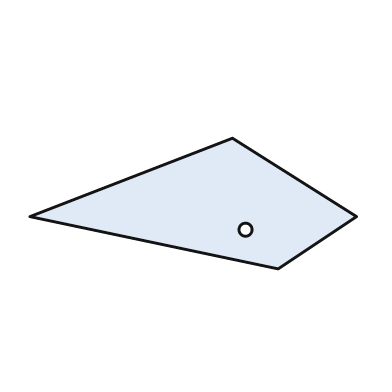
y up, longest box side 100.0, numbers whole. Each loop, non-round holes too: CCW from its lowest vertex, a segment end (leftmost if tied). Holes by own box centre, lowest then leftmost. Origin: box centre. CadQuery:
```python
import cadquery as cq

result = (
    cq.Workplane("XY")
    .moveTo(26.0, -20.0)
    .lineTo(50.0, -4.0)
    .lineTo(12.0, 20.0)
    .lineTo(-50.0, -4.0)
    .close()
    .moveTo(16.0, -8.0)
    .circle(2.0)
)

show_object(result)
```